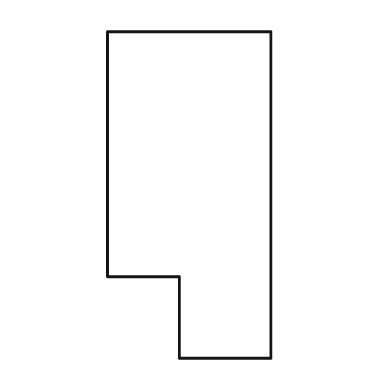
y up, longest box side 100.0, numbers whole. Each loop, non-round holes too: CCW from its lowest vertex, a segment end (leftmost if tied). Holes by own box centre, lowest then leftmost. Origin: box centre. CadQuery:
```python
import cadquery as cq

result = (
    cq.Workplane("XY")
    .moveTo(-3.0, -50.0)
    .lineTo(25.0, -50.0)
    .lineTo(25.0, 50.0)
    .lineTo(-25.0, 50.0)
    .lineTo(-25.0, -25.0)
    .lineTo(-3.0, -25.0)
    .close()
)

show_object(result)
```